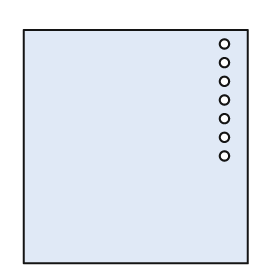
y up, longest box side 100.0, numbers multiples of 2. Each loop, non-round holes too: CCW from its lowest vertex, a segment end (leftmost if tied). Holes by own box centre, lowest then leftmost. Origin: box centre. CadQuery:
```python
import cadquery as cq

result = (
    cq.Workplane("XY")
    .moveTo(-48.0, -50.0)
    .lineTo(48.0, -50.0)
    .lineTo(48.0, 50.0)
    .lineTo(-48.0, 50.0)
    .close()
    .moveTo(38.0, -4.0)
    .circle(2.0)
    .moveTo(38.0, 4.0)
    .circle(2.0)
    .moveTo(38.0, 12.0)
    .circle(2.0)
    .moveTo(38.0, 20.0)
    .circle(2.0)
    .moveTo(38.0, 28.0)
    .circle(2.0)
    .moveTo(38.0, 36.0)
    .circle(2.0)
    .moveTo(38.0, 44.0)
    .circle(2.0)
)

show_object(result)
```